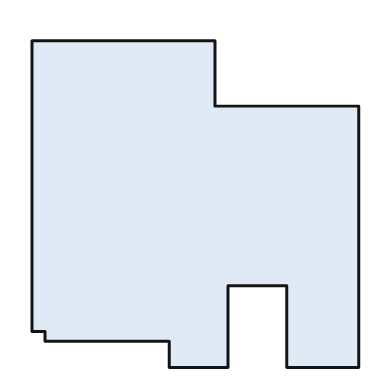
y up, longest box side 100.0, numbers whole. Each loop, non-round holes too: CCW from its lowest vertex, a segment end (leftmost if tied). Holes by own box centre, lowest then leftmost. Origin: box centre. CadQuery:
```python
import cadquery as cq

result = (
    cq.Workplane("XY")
    .moveTo(-8.0, -50.0)
    .lineTo(10.0, -50.0)
    .lineTo(10.0, -25.0)
    .lineTo(28.0, -25.0)
    .lineTo(28.0, -50.0)
    .lineTo(50.0, -50.0)
    .lineTo(50.0, 30.0)
    .lineTo(6.0, 30.0)
    .lineTo(6.0, 50.0)
    .lineTo(-50.0, 50.0)
    .lineTo(-50.0, -39.0)
    .lineTo(-46.0, -39.0)
    .lineTo(-46.0, -42.0)
    .lineTo(-8.0, -42.0)
    .close()
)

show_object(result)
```